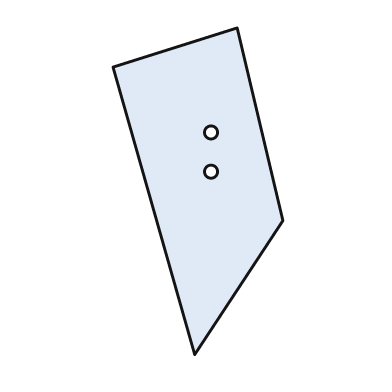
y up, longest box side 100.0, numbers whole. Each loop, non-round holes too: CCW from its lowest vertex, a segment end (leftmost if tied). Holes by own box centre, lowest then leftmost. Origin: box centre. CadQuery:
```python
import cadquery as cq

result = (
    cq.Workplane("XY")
    .moveTo(-1.0, -50.0)
    .lineTo(26.0, -9.0)
    .lineTo(12.0, 50.0)
    .lineTo(-26.0, 38.0)
    .close()
    .moveTo(4.0, 6.0)
    .circle(2.0)
    .moveTo(4.0, 18.0)
    .circle(2.0)
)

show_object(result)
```